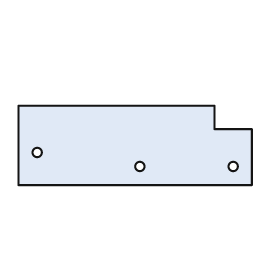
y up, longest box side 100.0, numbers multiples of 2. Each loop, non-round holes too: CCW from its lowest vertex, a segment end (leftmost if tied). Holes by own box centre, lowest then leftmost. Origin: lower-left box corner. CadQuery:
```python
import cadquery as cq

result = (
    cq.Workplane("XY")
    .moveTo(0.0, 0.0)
    .lineTo(100.0, 0.0)
    .lineTo(100.0, 24.0)
    .lineTo(84.0, 24.0)
    .lineTo(84.0, 34.0)
    .lineTo(0.0, 34.0)
    .close()
    .moveTo(52.0, 8.0)
    .circle(2.0)
    .moveTo(92.0, 8.0)
    .circle(2.0)
    .moveTo(8.0, 14.0)
    .circle(2.0)
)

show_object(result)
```